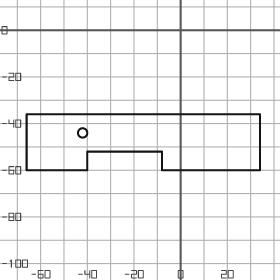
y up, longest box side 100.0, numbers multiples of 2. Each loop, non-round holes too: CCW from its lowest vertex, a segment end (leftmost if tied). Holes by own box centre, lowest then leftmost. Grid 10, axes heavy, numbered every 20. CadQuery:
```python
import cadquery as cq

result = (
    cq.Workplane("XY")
    .moveTo(-66.0, -60.0)
    .lineTo(-40.0, -60.0)
    .lineTo(-40.0, -52.0)
    .lineTo(-8.0, -52.0)
    .lineTo(-8.0, -60.0)
    .lineTo(34.0, -60.0)
    .lineTo(34.0, -36.0)
    .lineTo(-66.0, -36.0)
    .close()
    .moveTo(-42.0, -44.0)
    .circle(2.0)
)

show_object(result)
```